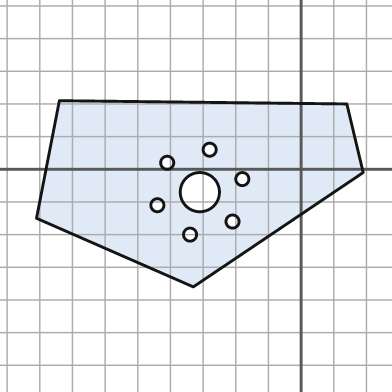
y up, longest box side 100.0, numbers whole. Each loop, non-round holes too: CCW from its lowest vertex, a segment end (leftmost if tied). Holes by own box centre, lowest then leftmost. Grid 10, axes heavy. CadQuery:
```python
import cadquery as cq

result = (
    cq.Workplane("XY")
    .moveTo(-33.0, -36.0)
    .lineTo(19.0, -1.0)
    .lineTo(14.0, 20.0)
    .lineTo(-74.0, 21.0)
    .lineTo(-81.0, -15.0)
    .close()
    .moveTo(-34.0, -20.0)
    .circle(2.0)
    .moveTo(-21.0, -16.0)
    .circle(2.0)
    .moveTo(-44.0, -11.0)
    .circle(2.0)
    .moveTo(-31.0, -7.0)
    .circle(6.0)
    .moveTo(-18.0, -3.0)
    .circle(2.0)
    .moveTo(-41.0, 2.0)
    .circle(2.0)
    .moveTo(-28.0, 6.0)
    .circle(2.0)
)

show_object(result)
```